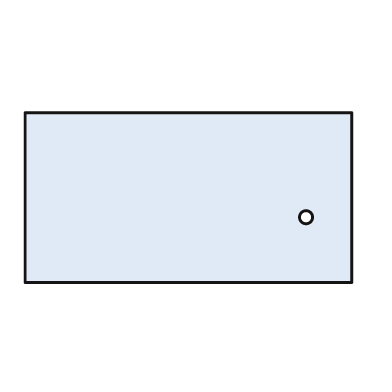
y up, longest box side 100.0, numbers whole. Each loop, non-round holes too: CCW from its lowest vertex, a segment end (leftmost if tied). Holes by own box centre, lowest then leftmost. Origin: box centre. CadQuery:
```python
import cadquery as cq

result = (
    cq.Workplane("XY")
    .moveTo(-50.0, -26.0)
    .lineTo(50.0, -26.0)
    .lineTo(50.0, 26.0)
    .lineTo(-50.0, 26.0)
    .close()
    .moveTo(36.0, -6.0)
    .circle(2.0)
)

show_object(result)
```